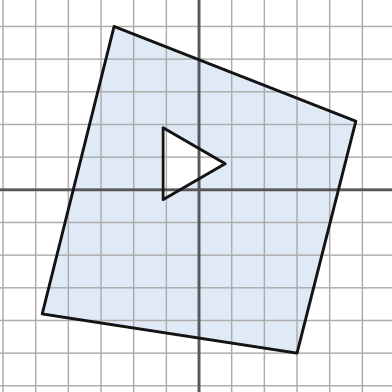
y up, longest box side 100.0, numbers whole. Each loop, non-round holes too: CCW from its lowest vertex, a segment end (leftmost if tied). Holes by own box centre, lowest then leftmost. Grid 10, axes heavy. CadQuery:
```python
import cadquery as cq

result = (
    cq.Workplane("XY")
    .moveTo(30.0, -50.0)
    .lineTo(48.0, 21.0)
    .lineTo(-26.0, 50.0)
    .lineTo(-48.0, -38.0)
    .close()
    .moveTo(-11.0, -3.0)
    .lineTo(8.0, 8.0)
    .lineTo(-11.0, 19.0)
    .close()
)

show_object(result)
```